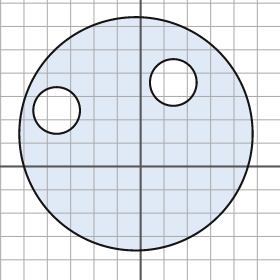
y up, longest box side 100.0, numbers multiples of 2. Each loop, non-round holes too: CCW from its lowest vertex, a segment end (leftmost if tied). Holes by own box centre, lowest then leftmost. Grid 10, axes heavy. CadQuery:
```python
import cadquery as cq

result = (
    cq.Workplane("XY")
    .moveTo(-2.0, 14.0)
    .circle(50.0)
    .moveTo(-36.0, 24.0)
    .circle(10.0)
    .moveTo(14.0, 36.0)
    .circle(10.0)
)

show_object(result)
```